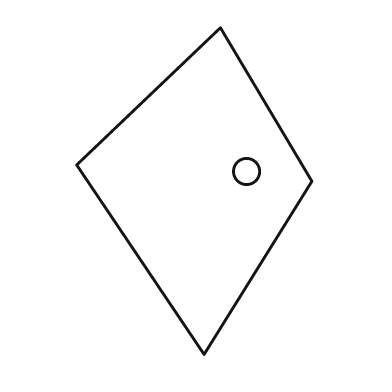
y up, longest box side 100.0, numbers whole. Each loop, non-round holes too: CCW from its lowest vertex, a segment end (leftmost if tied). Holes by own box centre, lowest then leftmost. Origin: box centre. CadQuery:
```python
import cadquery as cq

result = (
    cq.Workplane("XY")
    .moveTo(3.0, -50.0)
    .lineTo(36.0, 3.0)
    .lineTo(8.0, 50.0)
    .lineTo(-36.0, 8.0)
    .close()
    .moveTo(16.0, 6.0)
    .circle(4.0)
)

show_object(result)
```